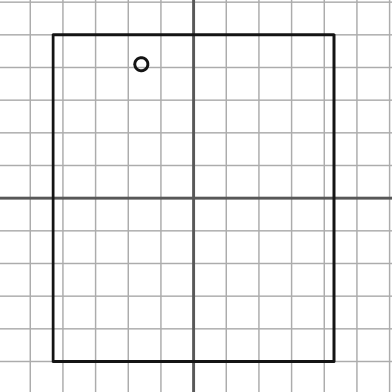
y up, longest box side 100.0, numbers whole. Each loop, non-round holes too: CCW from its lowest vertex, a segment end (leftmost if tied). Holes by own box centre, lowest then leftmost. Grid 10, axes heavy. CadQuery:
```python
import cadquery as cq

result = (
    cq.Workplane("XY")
    .moveTo(-43.0, -50.0)
    .lineTo(43.0, -50.0)
    .lineTo(43.0, 50.0)
    .lineTo(-43.0, 50.0)
    .close()
    .moveTo(-16.0, 41.0)
    .circle(2.0)
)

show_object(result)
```